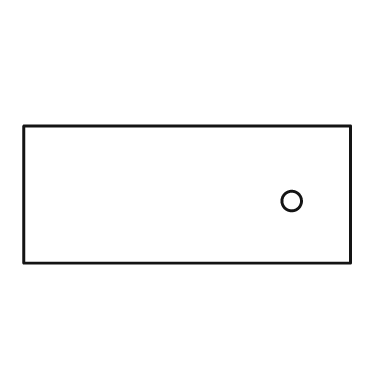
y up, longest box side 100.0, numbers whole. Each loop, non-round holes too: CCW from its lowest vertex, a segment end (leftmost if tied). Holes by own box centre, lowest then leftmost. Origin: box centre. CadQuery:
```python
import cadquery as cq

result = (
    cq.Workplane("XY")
    .moveTo(-50.0, -21.0)
    .lineTo(50.0, -21.0)
    .lineTo(50.0, 21.0)
    .lineTo(-50.0, 21.0)
    .close()
    .moveTo(32.0, -2.0)
    .circle(3.0)
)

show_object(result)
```